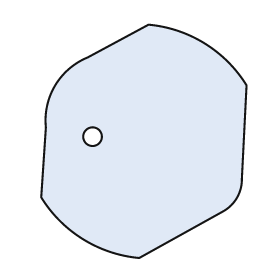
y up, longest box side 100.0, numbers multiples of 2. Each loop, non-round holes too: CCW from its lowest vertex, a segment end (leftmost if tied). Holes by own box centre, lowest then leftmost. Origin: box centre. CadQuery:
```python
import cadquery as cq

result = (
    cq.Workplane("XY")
    .moveTo(-2.0, -50.0)
    .lineTo(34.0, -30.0)
    .threePointArc((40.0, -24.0), (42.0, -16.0))
    .lineTo(44.0, 24.0)
    .threePointArc((26.0, 42.0), (2.0, 50.0))
    .lineTo(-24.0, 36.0)
    .threePointArc((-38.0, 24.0), (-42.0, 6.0))
    .lineTo(-44.0, -24.0)
    .threePointArc((-26.0, -42.0), (-2.0, -50.0))
    .close()
    .moveTo(-22.0, 2.0)
    .circle(4.0)
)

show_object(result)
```